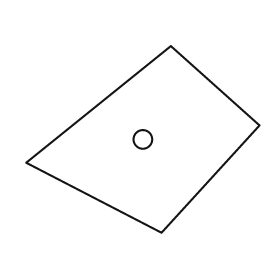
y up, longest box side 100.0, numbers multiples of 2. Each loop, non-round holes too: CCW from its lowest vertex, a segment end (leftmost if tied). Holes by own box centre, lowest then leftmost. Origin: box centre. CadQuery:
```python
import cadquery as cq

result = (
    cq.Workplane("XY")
    .moveTo(8.0, -40.0)
    .lineTo(50.0, 6.0)
    .lineTo(12.0, 40.0)
    .lineTo(-50.0, -10.0)
    .close()
    .moveTo(0.0, 0.0)
    .circle(4.0)
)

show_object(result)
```